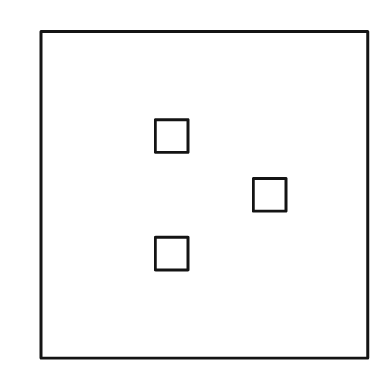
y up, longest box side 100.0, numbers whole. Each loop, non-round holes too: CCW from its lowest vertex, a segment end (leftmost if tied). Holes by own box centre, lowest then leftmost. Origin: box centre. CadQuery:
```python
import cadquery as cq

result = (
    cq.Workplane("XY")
    .moveTo(-50.0, -50.0)
    .lineTo(50.0, -50.0)
    .lineTo(50.0, 50.0)
    .lineTo(-50.0, 50.0)
    .close()
    .moveTo(-15.0, -23.0)
    .lineTo(-5.0, -23.0)
    .lineTo(-5.0, -13.0)
    .lineTo(-15.0, -13.0)
    .close()
    .moveTo(15.0, -5.0)
    .lineTo(25.0, -5.0)
    .lineTo(25.0, 5.0)
    .lineTo(15.0, 5.0)
    .close()
    .moveTo(-15.0, 13.0)
    .lineTo(-5.0, 13.0)
    .lineTo(-5.0, 23.0)
    .lineTo(-15.0, 23.0)
    .close()
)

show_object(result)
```